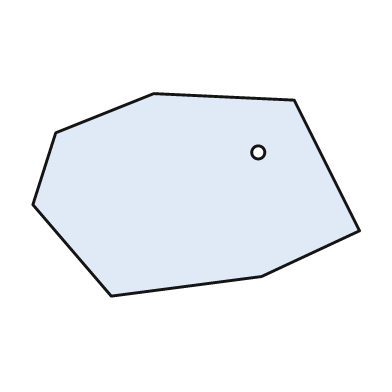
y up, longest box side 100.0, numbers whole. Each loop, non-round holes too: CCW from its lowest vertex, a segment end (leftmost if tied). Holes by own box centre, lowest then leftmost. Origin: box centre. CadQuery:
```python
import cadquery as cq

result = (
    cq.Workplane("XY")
    .moveTo(-26.0, -31.0)
    .lineTo(20.0, -25.0)
    .lineTo(50.0, -11.0)
    .lineTo(30.0, 29.0)
    .lineTo(-13.0, 31.0)
    .lineTo(-43.0, 19.0)
    .lineTo(-50.0, -3.0)
    .close()
    .moveTo(19.0, 13.0)
    .circle(2.0)
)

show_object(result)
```